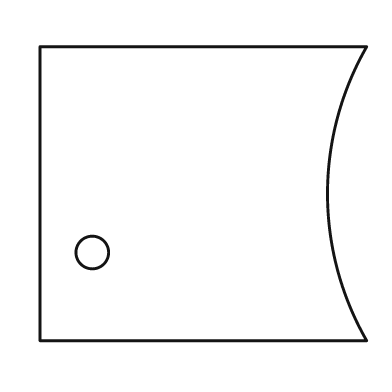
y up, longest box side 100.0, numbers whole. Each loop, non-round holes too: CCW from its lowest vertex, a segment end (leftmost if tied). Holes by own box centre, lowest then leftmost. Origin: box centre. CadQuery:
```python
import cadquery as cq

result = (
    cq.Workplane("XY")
    .moveTo(-50.0, -45.0)
    .lineTo(50.0, -45.0)
    .threePointArc((38.0, 0.0), (50.0, 45.0))
    .lineTo(-50.0, 45.0)
    .close()
    .moveTo(-34.0, -18.0)
    .circle(5.0)
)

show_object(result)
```